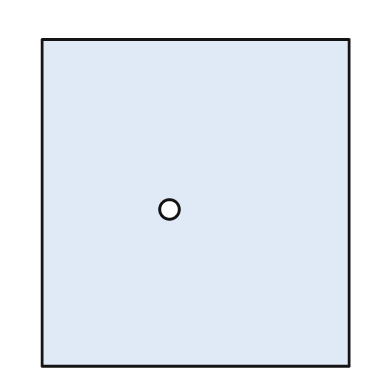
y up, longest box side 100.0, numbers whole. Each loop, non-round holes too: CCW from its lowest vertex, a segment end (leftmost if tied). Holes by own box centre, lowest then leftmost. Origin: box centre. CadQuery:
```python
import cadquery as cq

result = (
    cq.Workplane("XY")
    .moveTo(-47.0, -50.0)
    .lineTo(47.0, -50.0)
    .lineTo(47.0, 50.0)
    .lineTo(-47.0, 50.0)
    .close()
    .moveTo(-8.0, -2.0)
    .circle(3.0)
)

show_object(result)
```